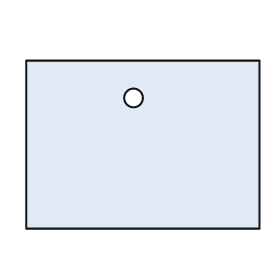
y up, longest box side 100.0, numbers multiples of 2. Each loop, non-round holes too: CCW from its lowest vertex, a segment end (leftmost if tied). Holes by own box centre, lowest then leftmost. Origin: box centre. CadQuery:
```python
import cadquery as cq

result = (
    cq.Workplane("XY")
    .moveTo(-50.0, -36.0)
    .lineTo(50.0, -36.0)
    .lineTo(50.0, 36.0)
    .lineTo(-50.0, 36.0)
    .close()
    .moveTo(-4.0, 20.0)
    .circle(4.0)
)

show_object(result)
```